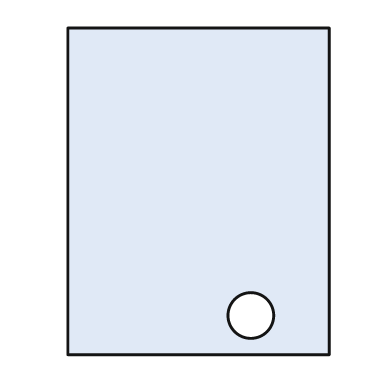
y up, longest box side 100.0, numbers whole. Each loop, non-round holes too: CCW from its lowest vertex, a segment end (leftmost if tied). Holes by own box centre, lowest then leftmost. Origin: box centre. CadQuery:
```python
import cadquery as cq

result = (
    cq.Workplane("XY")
    .moveTo(-40.0, -50.0)
    .lineTo(40.0, -50.0)
    .lineTo(40.0, 50.0)
    .lineTo(-40.0, 50.0)
    .close()
    .moveTo(16.0, -38.0)
    .circle(7.0)
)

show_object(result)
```